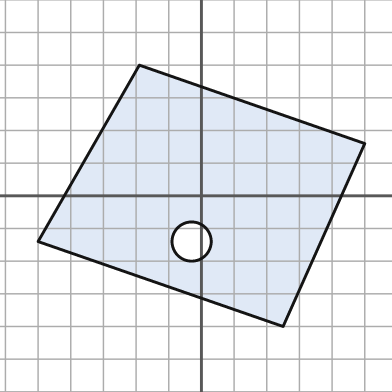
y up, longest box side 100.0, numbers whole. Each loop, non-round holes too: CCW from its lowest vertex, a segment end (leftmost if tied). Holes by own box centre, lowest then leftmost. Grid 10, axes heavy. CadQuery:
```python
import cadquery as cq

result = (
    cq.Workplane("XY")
    .moveTo(25.0, -40.0)
    .lineTo(50.0, 16.0)
    .lineTo(-19.0, 40.0)
    .lineTo(-50.0, -14.0)
    .close()
    .moveTo(-3.0, -14.0)
    .circle(6.0)
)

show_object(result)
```